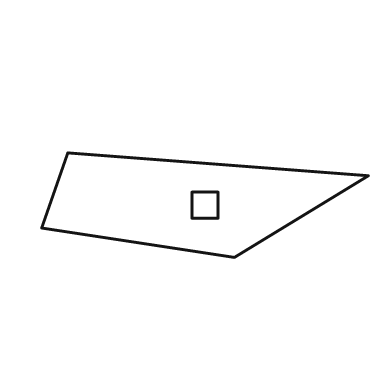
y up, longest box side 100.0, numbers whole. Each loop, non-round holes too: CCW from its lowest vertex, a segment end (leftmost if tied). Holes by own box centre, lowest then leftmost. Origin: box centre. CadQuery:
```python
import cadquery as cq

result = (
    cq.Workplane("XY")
    .moveTo(9.0, -16.0)
    .lineTo(50.0, 9.0)
    .lineTo(-42.0, 16.0)
    .lineTo(-50.0, -7.0)
    .close()
    .moveTo(-4.0, -4.0)
    .lineTo(4.0, -4.0)
    .lineTo(4.0, 4.0)
    .lineTo(-4.0, 4.0)
    .close()
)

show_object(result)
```